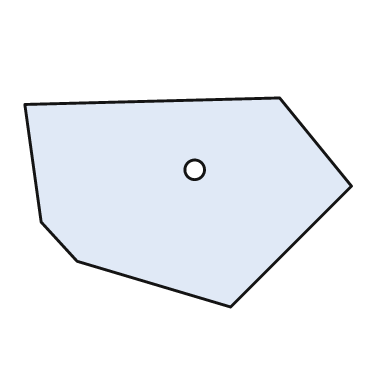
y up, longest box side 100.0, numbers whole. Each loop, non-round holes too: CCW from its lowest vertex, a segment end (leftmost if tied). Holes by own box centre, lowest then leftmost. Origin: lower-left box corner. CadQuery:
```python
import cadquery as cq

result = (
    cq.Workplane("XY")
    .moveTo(63.0, 0.0)
    .lineTo(100.0, 37.0)
    .lineTo(78.0, 64.0)
    .lineTo(0.0, 62.0)
    .lineTo(5.0, 26.0)
    .lineTo(16.0, 14.0)
    .close()
    .moveTo(52.0, 42.0)
    .circle(3.0)
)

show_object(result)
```